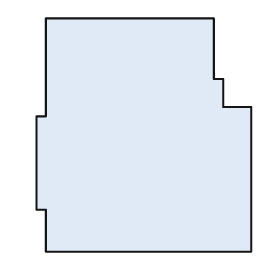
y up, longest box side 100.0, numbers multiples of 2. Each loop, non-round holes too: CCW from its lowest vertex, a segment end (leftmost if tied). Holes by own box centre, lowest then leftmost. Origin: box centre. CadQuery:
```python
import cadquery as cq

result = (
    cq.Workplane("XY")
    .moveTo(-42.0, -50.0)
    .lineTo(46.0, -50.0)
    .lineTo(46.0, 12.0)
    .lineTo(34.0, 12.0)
    .lineTo(34.0, 24.0)
    .lineTo(30.0, 24.0)
    .lineTo(30.0, 50.0)
    .lineTo(-42.0, 50.0)
    .lineTo(-42.0, 8.0)
    .lineTo(-46.0, 8.0)
    .lineTo(-46.0, -32.0)
    .lineTo(-42.0, -32.0)
    .close()
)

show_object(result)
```